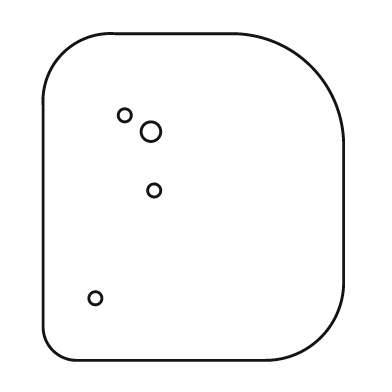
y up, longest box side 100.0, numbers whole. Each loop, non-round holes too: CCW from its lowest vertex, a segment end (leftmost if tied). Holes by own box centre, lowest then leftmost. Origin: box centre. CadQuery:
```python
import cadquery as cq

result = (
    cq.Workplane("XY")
    .moveTo(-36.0, -50.0)
    .lineTo(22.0, -50.0)
    .threePointArc((39.0, -43.0), (46.0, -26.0))
    .lineTo(46.0, 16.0)
    .threePointArc((36.0, 40.0), (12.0, 50.0))
    .lineTo(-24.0, 50.0)
    .threePointArc((-40.0, 44.0), (-46.0, 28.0))
    .lineTo(-46.0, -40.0)
    .threePointArc((-43.0, -47.0), (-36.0, -50.0))
    .close()
    .moveTo(-30.0, -31.0)
    .circle(2.0)
    .moveTo(-12.0, 2.0)
    .circle(2.0)
    .moveTo(-13.0, 20.0)
    .circle(3.0)
    .moveTo(-21.0, 25.0)
    .circle(2.0)
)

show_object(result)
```